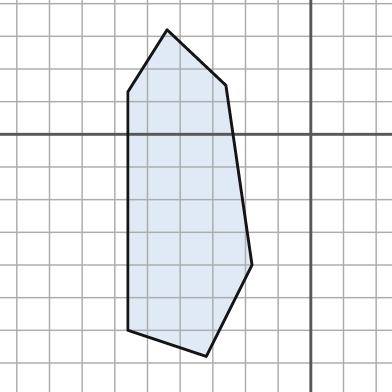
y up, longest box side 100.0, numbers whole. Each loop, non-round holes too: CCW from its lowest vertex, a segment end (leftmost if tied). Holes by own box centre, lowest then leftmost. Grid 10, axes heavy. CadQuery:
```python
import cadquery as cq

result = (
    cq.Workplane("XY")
    .moveTo(-32.0, -68.0)
    .lineTo(-18.0, -40.0)
    .lineTo(-26.0, 15.0)
    .lineTo(-44.0, 32.0)
    .lineTo(-56.0, 13.0)
    .lineTo(-56.0, -60.0)
    .close()
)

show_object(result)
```